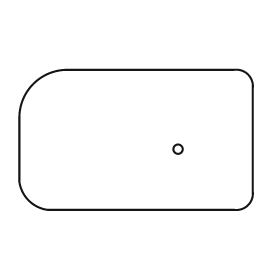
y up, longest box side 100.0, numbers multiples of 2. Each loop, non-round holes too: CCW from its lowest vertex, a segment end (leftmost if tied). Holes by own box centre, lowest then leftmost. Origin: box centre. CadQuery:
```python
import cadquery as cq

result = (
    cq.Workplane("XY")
    .moveTo(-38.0, -30.0)
    .lineTo(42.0, -30.0)
    .threePointArc((48.0, -28.0), (50.0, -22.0))
    .lineTo(50.0, 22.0)
    .threePointArc((48.0, 28.0), (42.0, 30.0))
    .lineTo(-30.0, 30.0)
    .threePointArc((-44.0, 24.0), (-50.0, 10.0))
    .lineTo(-50.0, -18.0)
    .threePointArc((-46.0, -26.0), (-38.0, -30.0))
    .close()
    .moveTo(18.0, -4.0)
    .circle(2.0)
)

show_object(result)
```